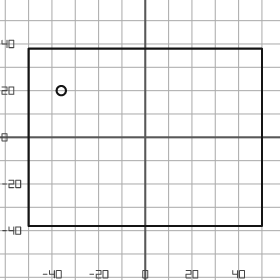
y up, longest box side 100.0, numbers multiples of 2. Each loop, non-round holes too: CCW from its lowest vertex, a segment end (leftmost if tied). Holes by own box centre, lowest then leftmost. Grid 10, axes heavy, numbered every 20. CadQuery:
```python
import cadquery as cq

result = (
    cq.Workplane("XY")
    .moveTo(-50.0, -38.0)
    .lineTo(50.0, -38.0)
    .lineTo(50.0, 38.0)
    .lineTo(-50.0, 38.0)
    .close()
    .moveTo(-36.0, 20.0)
    .circle(2.0)
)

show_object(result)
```